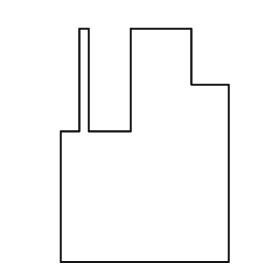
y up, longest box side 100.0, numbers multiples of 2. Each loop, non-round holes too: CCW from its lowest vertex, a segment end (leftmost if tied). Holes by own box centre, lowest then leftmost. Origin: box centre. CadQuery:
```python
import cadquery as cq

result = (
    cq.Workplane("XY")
    .moveTo(-36.0, -50.0)
    .lineTo(36.0, -50.0)
    .lineTo(36.0, 26.0)
    .lineTo(20.0, 26.0)
    .lineTo(20.0, 50.0)
    .lineTo(-6.0, 50.0)
    .lineTo(-6.0, 6.0)
    .lineTo(-24.0, 6.0)
    .lineTo(-24.0, 50.0)
    .lineTo(-28.0, 50.0)
    .lineTo(-28.0, 6.0)
    .lineTo(-36.0, 6.0)
    .close()
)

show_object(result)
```